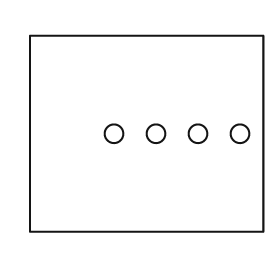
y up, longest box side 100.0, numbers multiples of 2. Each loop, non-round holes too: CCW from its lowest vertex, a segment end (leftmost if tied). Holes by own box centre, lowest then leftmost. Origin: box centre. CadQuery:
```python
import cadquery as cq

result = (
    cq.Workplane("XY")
    .moveTo(-50.0, -42.0)
    .lineTo(50.0, -42.0)
    .lineTo(50.0, 42.0)
    .lineTo(-50.0, 42.0)
    .close()
    .moveTo(-14.0, 0.0)
    .circle(4.0)
    .moveTo(4.0, 0.0)
    .circle(4.0)
    .moveTo(22.0, 0.0)
    .circle(4.0)
    .moveTo(40.0, 0.0)
    .circle(4.0)
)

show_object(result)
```